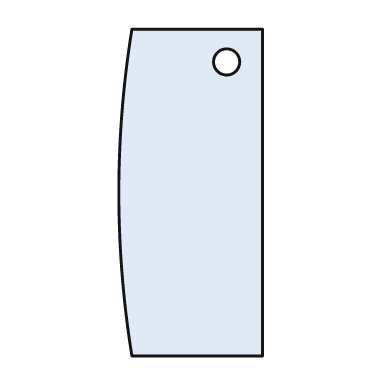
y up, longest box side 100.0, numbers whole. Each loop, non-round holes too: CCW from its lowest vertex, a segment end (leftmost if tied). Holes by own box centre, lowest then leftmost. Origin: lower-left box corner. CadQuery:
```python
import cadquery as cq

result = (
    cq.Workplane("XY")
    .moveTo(4.0, 0.0)
    .lineTo(44.0, 0.0)
    .lineTo(44.0, 100.0)
    .lineTo(4.0, 100.0)
    .threePointArc((0.0, 50.0), (4.0, 0.0))
    .close()
    .moveTo(33.0, 90.0)
    .circle(4.0)
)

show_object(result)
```